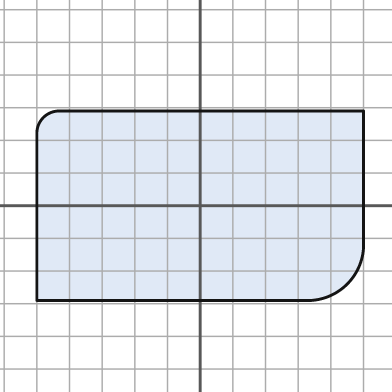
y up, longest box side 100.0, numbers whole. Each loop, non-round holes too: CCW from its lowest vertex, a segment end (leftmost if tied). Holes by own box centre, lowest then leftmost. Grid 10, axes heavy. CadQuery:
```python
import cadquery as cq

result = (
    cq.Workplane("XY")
    .moveTo(-50.0, -29.0)
    .lineTo(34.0, -29.0)
    .threePointArc((45.0, -24.0), (50.0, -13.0))
    .lineTo(50.0, 29.0)
    .lineTo(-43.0, 29.0)
    .threePointArc((-48.0, 27.0), (-50.0, 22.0))
    .close()
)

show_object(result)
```